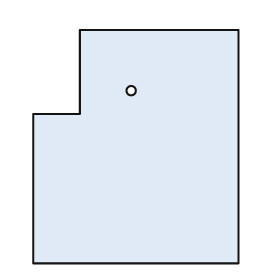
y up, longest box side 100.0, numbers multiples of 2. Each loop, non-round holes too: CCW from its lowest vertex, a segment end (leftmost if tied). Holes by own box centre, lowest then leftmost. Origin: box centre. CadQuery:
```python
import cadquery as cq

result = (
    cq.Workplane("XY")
    .moveTo(-44.0, -50.0)
    .lineTo(44.0, -50.0)
    .lineTo(44.0, 50.0)
    .lineTo(-24.0, 50.0)
    .lineTo(-24.0, 14.0)
    .lineTo(-44.0, 14.0)
    .close()
    .moveTo(-2.0, 24.0)
    .circle(2.0)
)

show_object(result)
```